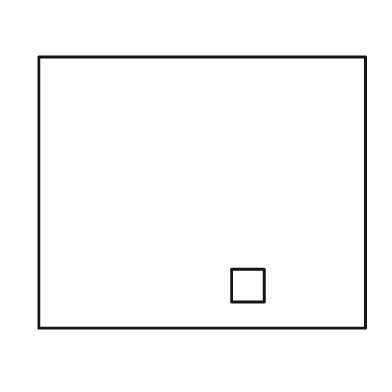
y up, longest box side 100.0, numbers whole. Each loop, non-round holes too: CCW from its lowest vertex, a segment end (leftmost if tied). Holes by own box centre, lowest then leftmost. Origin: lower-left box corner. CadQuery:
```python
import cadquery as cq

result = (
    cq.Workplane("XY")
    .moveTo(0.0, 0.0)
    .lineTo(100.0, 0.0)
    .lineTo(100.0, 83.0)
    .lineTo(0.0, 83.0)
    .close()
    .moveTo(59.0, 8.0)
    .lineTo(69.0, 8.0)
    .lineTo(69.0, 18.0)
    .lineTo(59.0, 18.0)
    .close()
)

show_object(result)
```